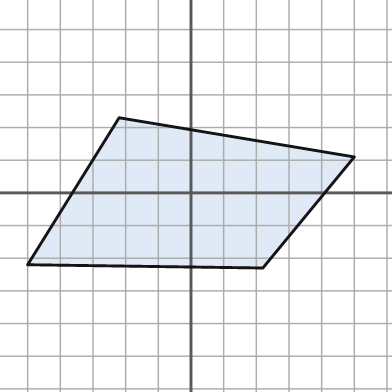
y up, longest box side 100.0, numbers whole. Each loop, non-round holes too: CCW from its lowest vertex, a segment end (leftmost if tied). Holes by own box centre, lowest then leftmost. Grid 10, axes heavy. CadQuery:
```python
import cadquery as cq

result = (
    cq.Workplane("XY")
    .moveTo(22.0, -23.0)
    .lineTo(50.0, 11.0)
    .lineTo(-22.0, 23.0)
    .lineTo(-50.0, -22.0)
    .close()
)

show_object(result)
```